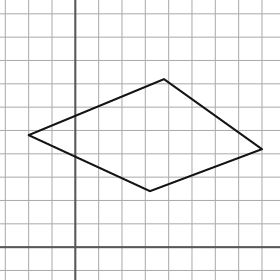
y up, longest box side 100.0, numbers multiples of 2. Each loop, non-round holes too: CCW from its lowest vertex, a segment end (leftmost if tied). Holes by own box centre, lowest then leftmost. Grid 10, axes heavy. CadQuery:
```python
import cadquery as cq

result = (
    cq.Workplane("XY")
    .moveTo(32.0, 24.0)
    .lineTo(80.0, 42.0)
    .lineTo(38.0, 72.0)
    .lineTo(-20.0, 48.0)
    .close()
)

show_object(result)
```